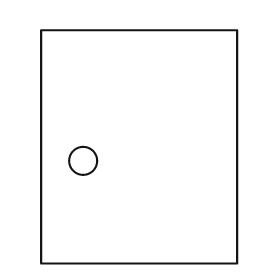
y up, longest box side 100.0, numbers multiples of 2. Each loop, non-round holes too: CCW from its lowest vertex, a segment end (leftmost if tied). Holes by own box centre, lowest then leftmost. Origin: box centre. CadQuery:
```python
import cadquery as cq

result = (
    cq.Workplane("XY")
    .moveTo(-42.0, -50.0)
    .lineTo(42.0, -50.0)
    .lineTo(42.0, 50.0)
    .lineTo(-42.0, 50.0)
    .close()
    .moveTo(-24.0, -6.0)
    .circle(6.0)
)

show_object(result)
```